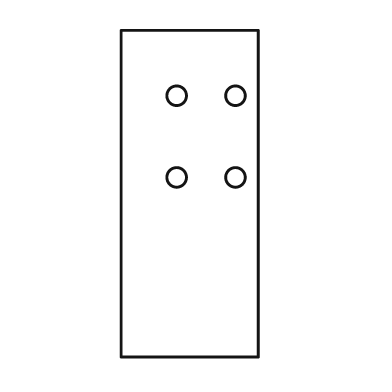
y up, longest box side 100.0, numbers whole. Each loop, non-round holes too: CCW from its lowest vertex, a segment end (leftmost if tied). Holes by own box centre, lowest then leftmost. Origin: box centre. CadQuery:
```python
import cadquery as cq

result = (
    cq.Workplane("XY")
    .moveTo(-21.0, -50.0)
    .lineTo(21.0, -50.0)
    .lineTo(21.0, 50.0)
    .lineTo(-21.0, 50.0)
    .close()
    .moveTo(-4.0, 5.0)
    .circle(3.0)
    .moveTo(14.0, 5.0)
    .circle(3.0)
    .moveTo(-4.0, 30.0)
    .circle(3.0)
    .moveTo(14.0, 30.0)
    .circle(3.0)
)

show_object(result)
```